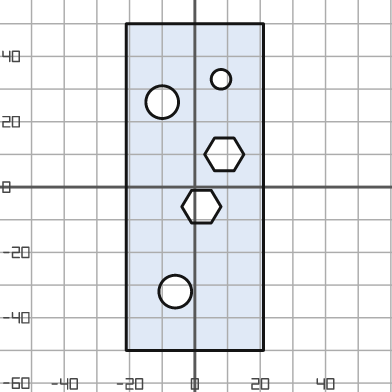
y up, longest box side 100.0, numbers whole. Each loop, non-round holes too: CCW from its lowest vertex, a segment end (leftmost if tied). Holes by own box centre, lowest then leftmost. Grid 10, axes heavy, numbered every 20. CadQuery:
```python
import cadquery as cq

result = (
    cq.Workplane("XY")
    .moveTo(-21.0, -50.0)
    .lineTo(21.0, -50.0)
    .lineTo(21.0, 50.0)
    .lineTo(-21.0, 50.0)
    .close()
    .moveTo(-6.0, -32.0)
    .circle(5.0)
    .moveTo(-1.0, -11.0)
    .lineTo(5.0, -11.0)
    .lineTo(8.0, -6.0)
    .lineTo(5.0, -1.0)
    .lineTo(-1.0, -1.0)
    .lineTo(-4.0, -6.0)
    .close()
    .moveTo(6.0, 5.0)
    .lineTo(12.0, 5.0)
    .lineTo(15.0, 10.0)
    .lineTo(12.0, 15.0)
    .lineTo(6.0, 15.0)
    .lineTo(3.0, 10.0)
    .close()
    .moveTo(-10.0, 26.0)
    .circle(5.0)
    .moveTo(8.0, 33.0)
    .circle(3.0)
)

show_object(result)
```